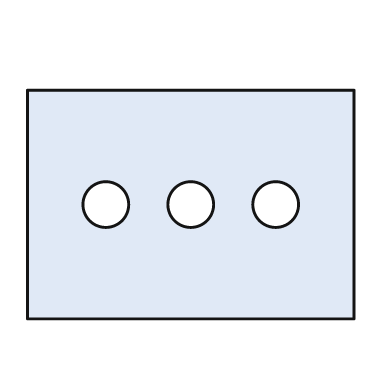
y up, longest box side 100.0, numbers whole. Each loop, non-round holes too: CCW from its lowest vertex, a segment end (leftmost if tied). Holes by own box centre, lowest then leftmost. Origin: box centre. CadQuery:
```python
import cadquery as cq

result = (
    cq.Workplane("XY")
    .moveTo(-50.0, -35.0)
    .lineTo(50.0, -35.0)
    .lineTo(50.0, 35.0)
    .lineTo(-50.0, 35.0)
    .close()
    .moveTo(-26.0, 0.0)
    .circle(7.0)
    .moveTo(0.0, 0.0)
    .circle(7.0)
    .moveTo(26.0, 0.0)
    .circle(7.0)
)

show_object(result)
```